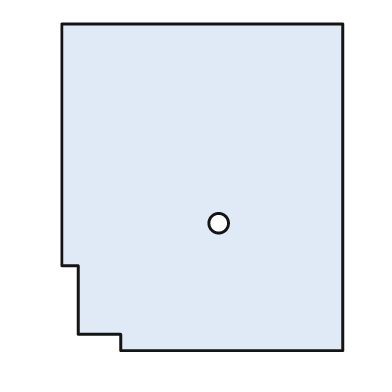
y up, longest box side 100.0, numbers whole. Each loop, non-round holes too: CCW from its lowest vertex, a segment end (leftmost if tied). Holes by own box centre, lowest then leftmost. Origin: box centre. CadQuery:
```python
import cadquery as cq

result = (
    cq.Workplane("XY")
    .moveTo(-25.0, -50.0)
    .lineTo(43.0, -50.0)
    .lineTo(43.0, 50.0)
    .lineTo(-43.0, 50.0)
    .lineTo(-43.0, -24.0)
    .lineTo(-38.0, -24.0)
    .lineTo(-38.0, -45.0)
    .lineTo(-25.0, -45.0)
    .close()
    .moveTo(5.0, -11.0)
    .circle(3.0)
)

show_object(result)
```